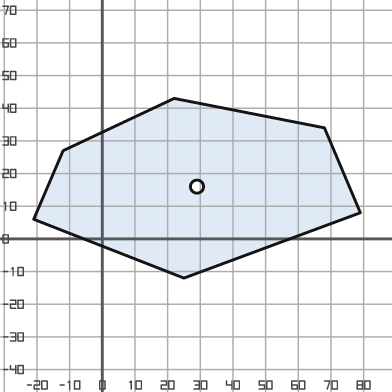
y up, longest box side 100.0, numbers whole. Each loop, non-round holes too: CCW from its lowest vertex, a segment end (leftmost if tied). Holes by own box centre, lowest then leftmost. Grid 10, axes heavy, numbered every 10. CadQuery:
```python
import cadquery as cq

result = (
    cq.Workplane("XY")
    .moveTo(25.0, -12.0)
    .lineTo(79.0, 8.0)
    .lineTo(68.0, 34.0)
    .lineTo(22.0, 43.0)
    .lineTo(-12.0, 27.0)
    .lineTo(-21.0, 6.0)
    .close()
    .moveTo(29.0, 16.0)
    .circle(2.0)
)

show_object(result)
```